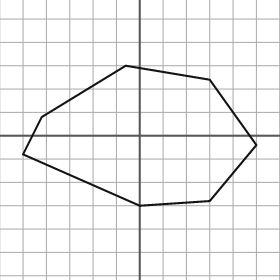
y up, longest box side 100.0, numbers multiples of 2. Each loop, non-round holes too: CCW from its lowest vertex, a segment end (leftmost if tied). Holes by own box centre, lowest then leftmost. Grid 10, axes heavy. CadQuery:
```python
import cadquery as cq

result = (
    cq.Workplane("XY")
    .moveTo(0.0, -30.0)
    .lineTo(30.0, -28.0)
    .lineTo(50.0, -4.0)
    .lineTo(30.0, 24.0)
    .lineTo(-6.0, 30.0)
    .lineTo(-42.0, 8.0)
    .lineTo(-50.0, -8.0)
    .close()
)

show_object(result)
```